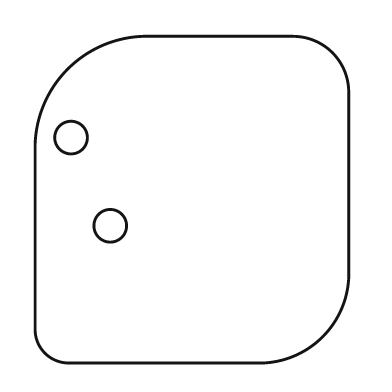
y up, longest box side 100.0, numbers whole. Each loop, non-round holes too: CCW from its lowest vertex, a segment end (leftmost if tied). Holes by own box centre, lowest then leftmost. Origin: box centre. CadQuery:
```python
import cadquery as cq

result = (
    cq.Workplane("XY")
    .moveTo(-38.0, -50.0)
    .lineTo(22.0, -50.0)
    .threePointArc((40.0, -42.0), (48.0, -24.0))
    .lineTo(48.0, 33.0)
    .threePointArc((43.0, 45.0), (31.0, 50.0))
    .lineTo(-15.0, 50.0)
    .threePointArc((-38.0, 40.0), (-48.0, 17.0))
    .lineTo(-48.0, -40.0)
    .threePointArc((-45.0, -47.0), (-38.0, -50.0))
    .close()
    .moveTo(-25.0, -8.0)
    .circle(5.0)
    .moveTo(-37.0, 19.0)
    .circle(5.0)
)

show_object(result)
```